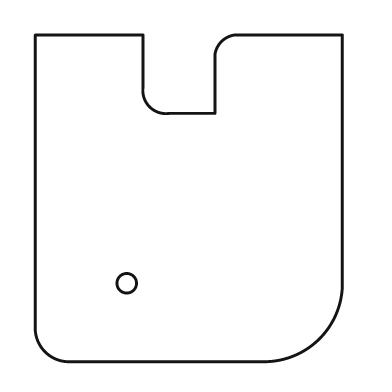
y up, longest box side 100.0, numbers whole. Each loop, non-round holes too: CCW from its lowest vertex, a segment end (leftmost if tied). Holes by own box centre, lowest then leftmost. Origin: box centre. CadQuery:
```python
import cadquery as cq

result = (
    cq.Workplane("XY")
    .moveTo(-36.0, -50.0)
    .lineTo(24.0, -50.0)
    .threePointArc((40.0, -43.0), (47.0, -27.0))
    .lineTo(47.0, 50.0)
    .lineTo(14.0, 50.0)
    .threePointArc((10.0, 48.0), (8.0, 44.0))
    .lineTo(8.0, 26.0)
    .lineTo(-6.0, 26.0)
    .threePointArc((-12.0, 28.0), (-14.0, 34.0))
    .lineTo(-14.0, 50.0)
    .lineTo(-47.0, 50.0)
    .lineTo(-47.0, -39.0)
    .threePointArc((-44.0, -47.0), (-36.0, -50.0))
    .close()
    .moveTo(-19.0, -26.0)
    .circle(3.0)
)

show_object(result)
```